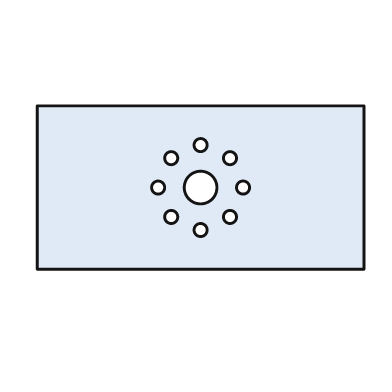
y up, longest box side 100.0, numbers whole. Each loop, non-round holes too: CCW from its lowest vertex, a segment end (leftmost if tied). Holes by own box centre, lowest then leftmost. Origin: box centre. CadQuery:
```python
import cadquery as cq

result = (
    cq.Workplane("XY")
    .moveTo(-50.0, -25.0)
    .lineTo(50.0, -25.0)
    .lineTo(50.0, 25.0)
    .lineTo(-50.0, 25.0)
    .close()
    .moveTo(0.0, -13.0)
    .circle(2.0)
    .moveTo(-9.0, -9.0)
    .circle(2.0)
    .moveTo(9.0, -9.0)
    .circle(2.0)
    .moveTo(-13.0, 0.0)
    .circle(2.0)
    .moveTo(0.0, 0.0)
    .circle(5.0)
    .moveTo(13.0, 0.0)
    .circle(2.0)
    .moveTo(-9.0, 9.0)
    .circle(2.0)
    .moveTo(9.0, 9.0)
    .circle(2.0)
    .moveTo(0.0, 13.0)
    .circle(2.0)
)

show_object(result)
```